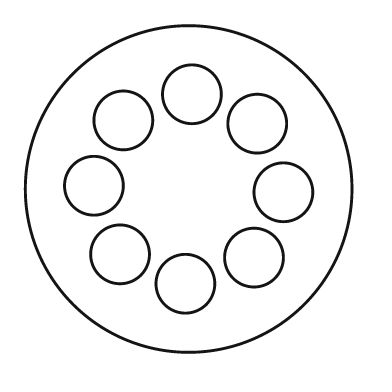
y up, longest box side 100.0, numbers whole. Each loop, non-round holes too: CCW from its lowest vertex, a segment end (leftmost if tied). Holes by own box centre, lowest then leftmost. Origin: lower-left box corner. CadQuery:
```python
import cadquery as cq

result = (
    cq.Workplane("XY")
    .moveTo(50.0, 50.0)
    .circle(50.0)
    .moveTo(49.0, 21.0)
    .circle(9.0)
    .moveTo(70.0, 29.0)
    .circle(9.0)
    .moveTo(29.0, 30.0)
    .circle(9.0)
    .moveTo(79.0, 49.0)
    .circle(9.0)
    .moveTo(21.0, 51.0)
    .circle(9.0)
    .moveTo(71.0, 70.0)
    .circle(9.0)
    .moveTo(30.0, 71.0)
    .circle(9.0)
    .moveTo(51.0, 79.0)
    .circle(9.0)
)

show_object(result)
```